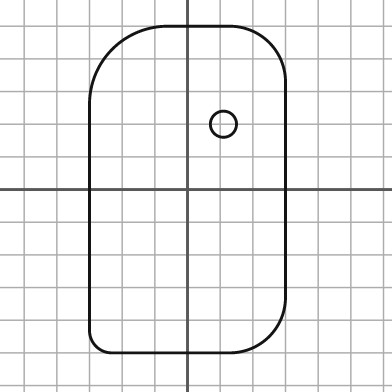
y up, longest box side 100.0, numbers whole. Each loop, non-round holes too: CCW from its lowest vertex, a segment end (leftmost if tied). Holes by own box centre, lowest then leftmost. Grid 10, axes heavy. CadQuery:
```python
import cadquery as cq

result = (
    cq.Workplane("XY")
    .moveTo(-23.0, -50.0)
    .lineTo(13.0, -50.0)
    .threePointArc((25.0, -45.0), (30.0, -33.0))
    .lineTo(30.0, 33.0)
    .threePointArc((25.0, 45.0), (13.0, 50.0))
    .lineTo(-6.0, 50.0)
    .threePointArc((-23.0, 43.0), (-30.0, 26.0))
    .lineTo(-30.0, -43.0)
    .threePointArc((-28.0, -48.0), (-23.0, -50.0))
    .close()
    .moveTo(11.0, 20.0)
    .circle(4.0)
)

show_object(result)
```